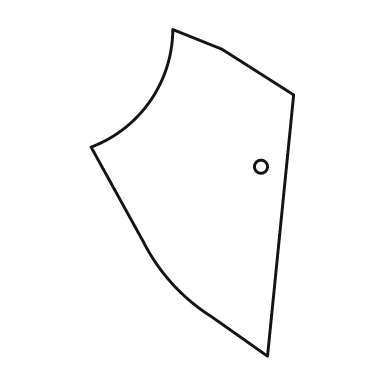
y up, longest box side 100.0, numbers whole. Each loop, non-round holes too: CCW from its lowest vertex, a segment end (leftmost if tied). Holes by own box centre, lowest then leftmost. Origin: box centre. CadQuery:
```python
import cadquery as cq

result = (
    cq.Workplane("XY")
    .moveTo(23.0, -50.0)
    .lineTo(31.0, 30.0)
    .lineTo(9.0, 44.0)
    .lineTo(-6.0, 50.0)
    .threePointArc((-13.0, 28.0), (-31.0, 14.0))
    .lineTo(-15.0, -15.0)
    .threePointArc((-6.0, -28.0), (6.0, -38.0))
    .close()
    .moveTo(21.0, 8.0)
    .circle(2.0)
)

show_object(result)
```